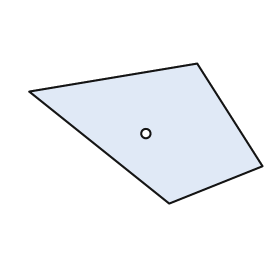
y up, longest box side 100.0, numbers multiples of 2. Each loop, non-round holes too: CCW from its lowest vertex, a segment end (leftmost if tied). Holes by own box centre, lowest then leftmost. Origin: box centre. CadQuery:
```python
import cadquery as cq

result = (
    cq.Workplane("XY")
    .moveTo(10.0, -30.0)
    .lineTo(50.0, -14.0)
    .lineTo(22.0, 30.0)
    .lineTo(-50.0, 18.0)
    .close()
    .moveTo(0.0, 0.0)
    .circle(2.0)
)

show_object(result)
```